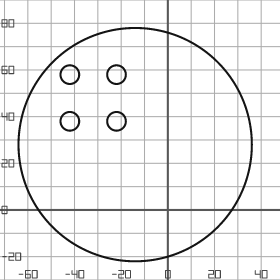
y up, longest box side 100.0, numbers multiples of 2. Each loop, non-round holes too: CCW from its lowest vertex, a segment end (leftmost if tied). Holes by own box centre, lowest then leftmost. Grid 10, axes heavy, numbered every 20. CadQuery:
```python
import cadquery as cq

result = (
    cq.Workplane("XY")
    .moveTo(-14.0, 28.0)
    .circle(50.0)
    .moveTo(-42.0, 38.0)
    .circle(4.0)
    .moveTo(-22.0, 38.0)
    .circle(4.0)
    .moveTo(-42.0, 58.0)
    .circle(4.0)
    .moveTo(-22.0, 58.0)
    .circle(4.0)
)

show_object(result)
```